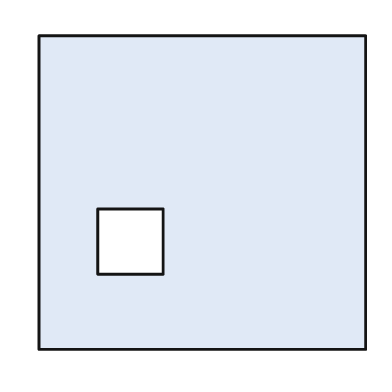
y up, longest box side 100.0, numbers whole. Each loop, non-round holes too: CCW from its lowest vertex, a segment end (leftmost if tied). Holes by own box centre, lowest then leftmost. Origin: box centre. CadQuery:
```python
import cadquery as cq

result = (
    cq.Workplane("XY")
    .moveTo(-50.0, -48.0)
    .lineTo(50.0, -48.0)
    .lineTo(50.0, 48.0)
    .lineTo(-50.0, 48.0)
    .close()
    .moveTo(-32.0, -25.0)
    .lineTo(-12.0, -25.0)
    .lineTo(-12.0, -5.0)
    .lineTo(-32.0, -5.0)
    .close()
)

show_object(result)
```